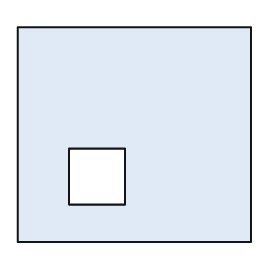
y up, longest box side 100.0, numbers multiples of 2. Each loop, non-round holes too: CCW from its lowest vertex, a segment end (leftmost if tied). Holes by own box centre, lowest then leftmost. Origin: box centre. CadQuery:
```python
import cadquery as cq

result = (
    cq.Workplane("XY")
    .moveTo(-50.0, -46.0)
    .lineTo(50.0, -46.0)
    .lineTo(50.0, 46.0)
    .lineTo(-50.0, 46.0)
    .close()
    .moveTo(-28.0, -30.0)
    .lineTo(-4.0, -30.0)
    .lineTo(-4.0, -6.0)
    .lineTo(-28.0, -6.0)
    .close()
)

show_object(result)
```